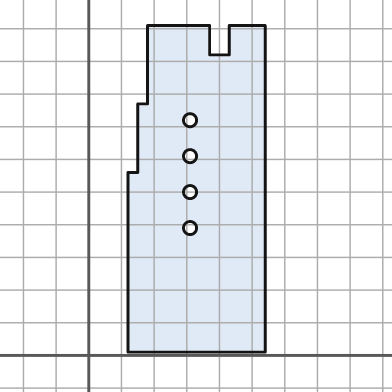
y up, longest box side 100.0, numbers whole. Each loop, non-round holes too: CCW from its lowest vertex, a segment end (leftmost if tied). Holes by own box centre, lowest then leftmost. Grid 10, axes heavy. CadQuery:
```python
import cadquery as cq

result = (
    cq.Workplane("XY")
    .moveTo(12.0, 1.0)
    .lineTo(54.0, 1.0)
    .lineTo(54.0, 101.0)
    .lineTo(43.0, 101.0)
    .lineTo(43.0, 92.0)
    .lineTo(37.0, 92.0)
    .lineTo(37.0, 101.0)
    .lineTo(18.0, 101.0)
    .lineTo(18.0, 77.0)
    .lineTo(15.0, 77.0)
    .lineTo(15.0, 56.0)
    .lineTo(12.0, 56.0)
    .close()
    .moveTo(31.0, 39.0)
    .circle(2.0)
    .moveTo(31.0, 50.0)
    .circle(2.0)
    .moveTo(31.0, 61.0)
    .circle(2.0)
    .moveTo(31.0, 72.0)
    .circle(2.0)
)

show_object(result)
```